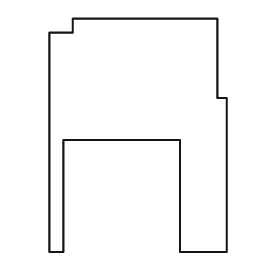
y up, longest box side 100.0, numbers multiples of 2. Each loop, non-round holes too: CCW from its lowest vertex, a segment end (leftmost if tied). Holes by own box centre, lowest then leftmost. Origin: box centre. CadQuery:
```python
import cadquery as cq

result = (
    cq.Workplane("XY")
    .moveTo(-38.0, -50.0)
    .lineTo(-32.0, -50.0)
    .lineTo(-32.0, -2.0)
    .lineTo(18.0, -2.0)
    .lineTo(18.0, -50.0)
    .lineTo(38.0, -50.0)
    .lineTo(38.0, 16.0)
    .lineTo(34.0, 16.0)
    .lineTo(34.0, 50.0)
    .lineTo(-28.0, 50.0)
    .lineTo(-28.0, 44.0)
    .lineTo(-38.0, 44.0)
    .close()
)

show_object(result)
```